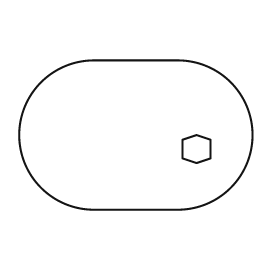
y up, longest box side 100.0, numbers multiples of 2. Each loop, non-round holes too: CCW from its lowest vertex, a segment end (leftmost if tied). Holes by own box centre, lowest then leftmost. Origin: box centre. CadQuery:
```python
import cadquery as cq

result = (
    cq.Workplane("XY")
    .moveTo(-18.0, -32.0)
    .lineTo(18.0, -32.0)
    .threePointArc((50.0, 0.0), (18.0, 32.0))
    .lineTo(-18.0, 32.0)
    .threePointArc((-50.0, 0.0), (-18.0, -32.0))
    .close()
    .moveTo(26.0, -12.0)
    .lineTo(32.0, -10.0)
    .lineTo(32.0, -2.0)
    .lineTo(26.0, 0.0)
    .lineTo(20.0, -2.0)
    .lineTo(20.0, -10.0)
    .close()
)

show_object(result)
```